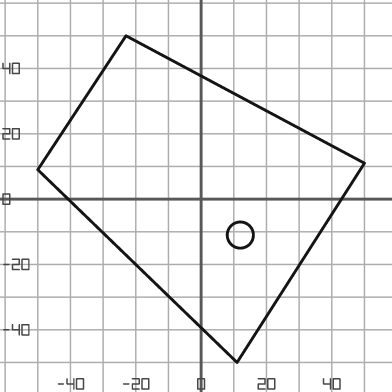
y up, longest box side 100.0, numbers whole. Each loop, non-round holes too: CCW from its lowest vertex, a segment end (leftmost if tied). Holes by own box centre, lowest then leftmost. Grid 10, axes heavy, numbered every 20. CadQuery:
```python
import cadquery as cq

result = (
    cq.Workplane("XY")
    .moveTo(11.0, -50.0)
    .lineTo(50.0, 11.0)
    .lineTo(-23.0, 50.0)
    .lineTo(-50.0, 9.0)
    .close()
    .moveTo(12.0, -11.0)
    .circle(4.0)
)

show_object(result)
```